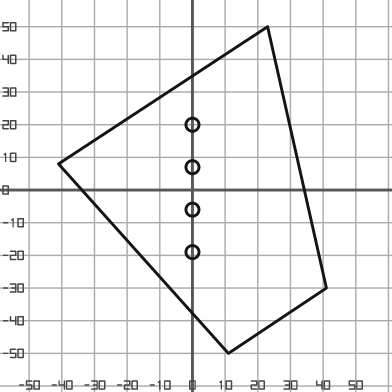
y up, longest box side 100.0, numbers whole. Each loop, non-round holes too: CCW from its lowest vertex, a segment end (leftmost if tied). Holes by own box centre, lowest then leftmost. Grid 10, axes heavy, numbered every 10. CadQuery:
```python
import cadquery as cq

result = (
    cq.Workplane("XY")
    .moveTo(11.0, -50.0)
    .lineTo(41.0, -30.0)
    .lineTo(23.0, 50.0)
    .lineTo(-41.0, 8.0)
    .close()
    .moveTo(0.0, -19.0)
    .circle(2.0)
    .moveTo(0.0, -6.0)
    .circle(2.0)
    .moveTo(0.0, 7.0)
    .circle(2.0)
    .moveTo(0.0, 20.0)
    .circle(2.0)
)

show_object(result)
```